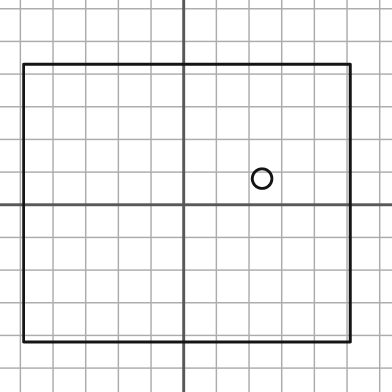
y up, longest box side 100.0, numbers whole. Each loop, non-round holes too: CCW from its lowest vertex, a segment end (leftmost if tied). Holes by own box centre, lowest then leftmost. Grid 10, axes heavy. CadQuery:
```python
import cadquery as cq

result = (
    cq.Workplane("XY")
    .moveTo(-49.0, -42.0)
    .lineTo(51.0, -42.0)
    .lineTo(51.0, 43.0)
    .lineTo(-49.0, 43.0)
    .close()
    .moveTo(24.0, 8.0)
    .circle(3.0)
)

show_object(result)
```